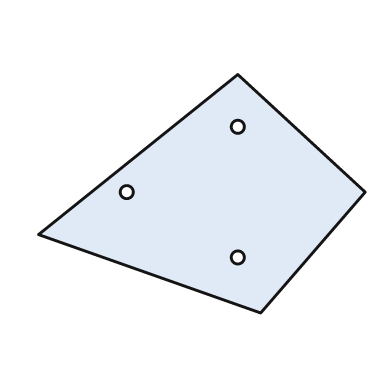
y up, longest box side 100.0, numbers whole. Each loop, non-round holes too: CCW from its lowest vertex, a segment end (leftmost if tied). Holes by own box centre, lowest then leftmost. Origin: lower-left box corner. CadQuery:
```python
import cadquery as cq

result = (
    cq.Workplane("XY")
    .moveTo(68.0, 0.0)
    .lineTo(100.0, 37.0)
    .lineTo(61.0, 73.0)
    .lineTo(0.0, 24.0)
    .close()
    .moveTo(61.0, 17.0)
    .circle(2.0)
    .moveTo(27.0, 37.0)
    .circle(2.0)
    .moveTo(61.0, 57.0)
    .circle(2.0)
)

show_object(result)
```